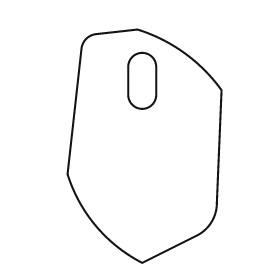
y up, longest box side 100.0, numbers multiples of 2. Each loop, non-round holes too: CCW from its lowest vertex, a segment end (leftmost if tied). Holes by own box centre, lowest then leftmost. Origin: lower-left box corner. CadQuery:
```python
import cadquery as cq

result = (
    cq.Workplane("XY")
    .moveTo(32.0, 0.0)
    .lineTo(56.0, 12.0)
    .threePointArc((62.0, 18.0), (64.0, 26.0))
    .lineTo(66.0, 74.0)
    .threePointArc((50.0, 90.0), (30.0, 100.0))
    .lineTo(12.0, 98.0)
    .threePointArc((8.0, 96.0), (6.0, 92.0))
    .lineTo(0.0, 38.0)
    .threePointArc((12.0, 16.0), (32.0, 0.0))
    .close()
    .moveTo(26.0, 72.0)
    .threePointArc((32.0, 66.0), (38.0, 72.0))
    .lineTo(38.0, 84.0)
    .threePointArc((32.0, 90.0), (26.0, 84.0))
    .close()
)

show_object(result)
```